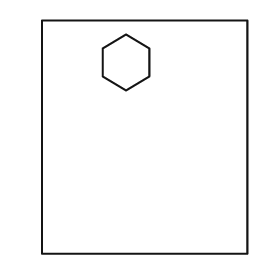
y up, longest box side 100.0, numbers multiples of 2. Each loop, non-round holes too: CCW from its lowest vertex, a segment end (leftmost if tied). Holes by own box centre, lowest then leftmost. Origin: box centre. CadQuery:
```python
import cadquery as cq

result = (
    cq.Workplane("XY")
    .moveTo(-44.0, -50.0)
    .lineTo(44.0, -50.0)
    .lineTo(44.0, 50.0)
    .lineTo(-44.0, 50.0)
    .close()
    .moveTo(-8.0, 20.0)
    .lineTo(2.0, 26.0)
    .lineTo(2.0, 38.0)
    .lineTo(-8.0, 44.0)
    .lineTo(-18.0, 38.0)
    .lineTo(-18.0, 26.0)
    .close()
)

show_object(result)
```